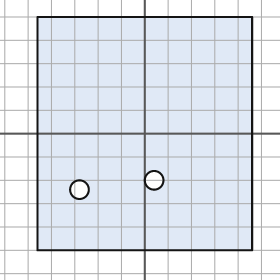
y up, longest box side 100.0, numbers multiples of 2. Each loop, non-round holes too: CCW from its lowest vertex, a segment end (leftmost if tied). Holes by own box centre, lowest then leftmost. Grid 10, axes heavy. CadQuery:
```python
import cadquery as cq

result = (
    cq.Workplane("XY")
    .moveTo(-46.0, -50.0)
    .lineTo(46.0, -50.0)
    .lineTo(46.0, 50.0)
    .lineTo(-46.0, 50.0)
    .close()
    .moveTo(-28.0, -24.0)
    .circle(4.0)
    .moveTo(4.0, -20.0)
    .circle(4.0)
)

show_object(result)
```